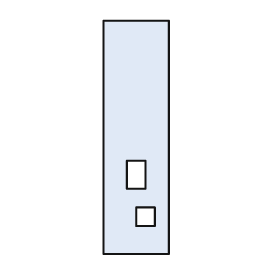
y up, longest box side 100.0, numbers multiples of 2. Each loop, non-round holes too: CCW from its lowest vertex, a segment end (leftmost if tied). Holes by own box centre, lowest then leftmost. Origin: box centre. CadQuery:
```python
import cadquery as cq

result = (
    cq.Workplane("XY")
    .moveTo(-14.0, -50.0)
    .lineTo(14.0, -50.0)
    .lineTo(14.0, 50.0)
    .lineTo(-14.0, 50.0)
    .close()
    .moveTo(0.0, -38.0)
    .lineTo(8.0, -38.0)
    .lineTo(8.0, -30.0)
    .lineTo(0.0, -30.0)
    .close()
    .moveTo(-4.0, -22.0)
    .lineTo(4.0, -22.0)
    .lineTo(4.0, -10.0)
    .lineTo(-4.0, -10.0)
    .close()
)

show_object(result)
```